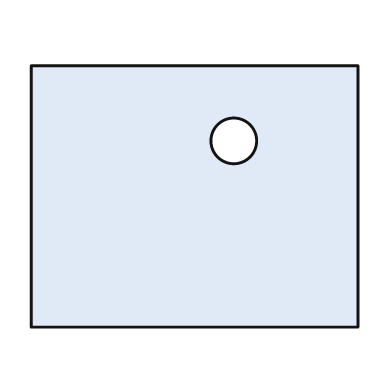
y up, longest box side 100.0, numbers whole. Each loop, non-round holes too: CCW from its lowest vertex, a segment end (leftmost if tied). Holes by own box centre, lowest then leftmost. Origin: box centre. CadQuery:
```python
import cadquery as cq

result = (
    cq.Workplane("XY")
    .moveTo(-50.0, -40.0)
    .lineTo(50.0, -40.0)
    .lineTo(50.0, 40.0)
    .lineTo(-50.0, 40.0)
    .close()
    .moveTo(12.0, 17.0)
    .circle(7.0)
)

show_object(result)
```